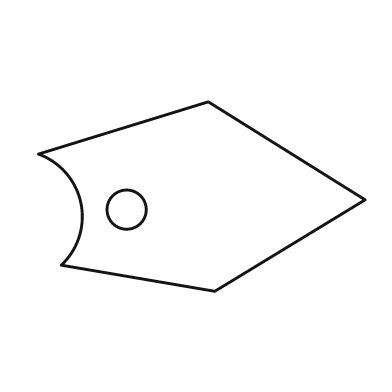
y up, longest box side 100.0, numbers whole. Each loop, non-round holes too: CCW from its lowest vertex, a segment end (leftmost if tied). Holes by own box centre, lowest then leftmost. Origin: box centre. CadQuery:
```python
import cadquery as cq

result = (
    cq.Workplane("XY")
    .moveTo(4.0, -29.0)
    .lineTo(50.0, -1.0)
    .lineTo(2.0, 29.0)
    .lineTo(-50.0, 13.0)
    .threePointArc((-37.0, -2.0), (-43.0, -21.0))
    .close()
    .moveTo(-23.0, -4.0)
    .circle(6.0)
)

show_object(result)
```